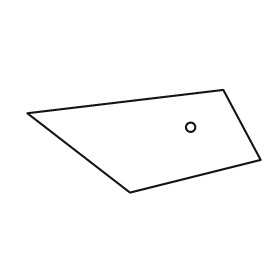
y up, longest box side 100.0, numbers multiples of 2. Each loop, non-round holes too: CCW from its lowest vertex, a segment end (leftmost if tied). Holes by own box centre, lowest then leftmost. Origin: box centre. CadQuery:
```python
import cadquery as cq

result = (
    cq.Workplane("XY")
    .moveTo(-6.0, -22.0)
    .lineTo(50.0, -8.0)
    .lineTo(34.0, 22.0)
    .lineTo(-50.0, 12.0)
    .close()
    .moveTo(20.0, 6.0)
    .circle(2.0)
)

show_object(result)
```